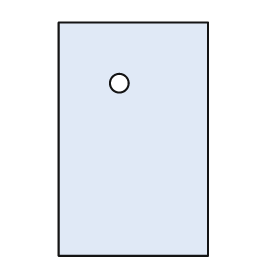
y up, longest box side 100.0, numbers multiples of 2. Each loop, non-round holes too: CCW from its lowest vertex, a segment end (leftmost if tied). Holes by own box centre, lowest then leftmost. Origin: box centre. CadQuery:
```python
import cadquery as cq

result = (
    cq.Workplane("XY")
    .moveTo(-32.0, -50.0)
    .lineTo(32.0, -50.0)
    .lineTo(32.0, 50.0)
    .lineTo(-32.0, 50.0)
    .close()
    .moveTo(-6.0, 24.0)
    .circle(4.0)
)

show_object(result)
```